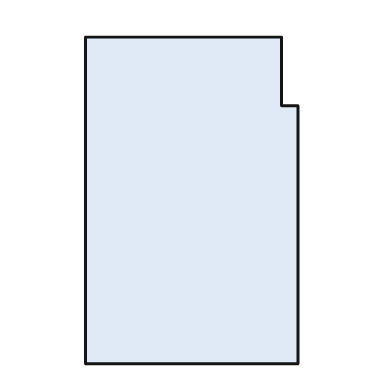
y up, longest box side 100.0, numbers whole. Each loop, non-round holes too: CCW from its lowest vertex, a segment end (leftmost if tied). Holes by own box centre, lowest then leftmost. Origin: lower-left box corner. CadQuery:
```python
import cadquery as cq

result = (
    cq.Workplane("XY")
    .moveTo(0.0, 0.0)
    .lineTo(65.0, 0.0)
    .lineTo(65.0, 79.0)
    .lineTo(60.0, 79.0)
    .lineTo(60.0, 100.0)
    .lineTo(0.0, 100.0)
    .close()
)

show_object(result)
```